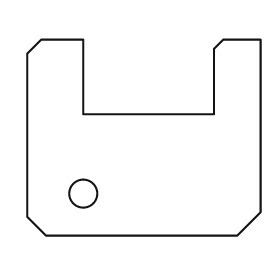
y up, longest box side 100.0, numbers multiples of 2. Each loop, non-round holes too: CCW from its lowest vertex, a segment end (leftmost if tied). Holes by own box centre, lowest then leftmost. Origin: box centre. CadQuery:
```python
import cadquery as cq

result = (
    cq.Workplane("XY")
    .moveTo(-42.0, -42.0)
    .lineTo(40.0, -42.0)
    .lineTo(50.0, -32.0)
    .lineTo(50.0, 42.0)
    .lineTo(34.0, 42.0)
    .lineTo(30.0, 38.0)
    .lineTo(30.0, 10.0)
    .lineTo(-26.0, 10.0)
    .lineTo(-26.0, 42.0)
    .lineTo(-44.0, 42.0)
    .lineTo(-50.0, 36.0)
    .lineTo(-50.0, -34.0)
    .close()
    .moveTo(-26.0, -24.0)
    .circle(6.0)
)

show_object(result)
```